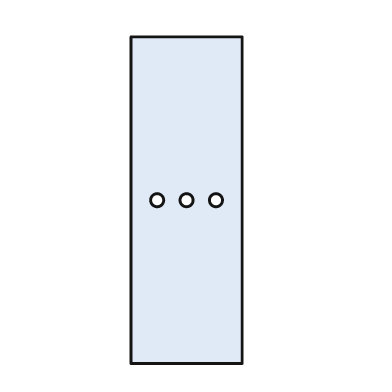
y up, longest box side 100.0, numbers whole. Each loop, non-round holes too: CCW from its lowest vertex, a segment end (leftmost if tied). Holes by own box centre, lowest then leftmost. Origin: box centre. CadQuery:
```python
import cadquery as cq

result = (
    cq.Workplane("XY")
    .moveTo(-17.0, -50.0)
    .lineTo(17.0, -50.0)
    .lineTo(17.0, 50.0)
    .lineTo(-17.0, 50.0)
    .close()
    .moveTo(-9.0, 0.0)
    .circle(2.0)
    .moveTo(0.0, 0.0)
    .circle(2.0)
    .moveTo(9.0, 0.0)
    .circle(2.0)
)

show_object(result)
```